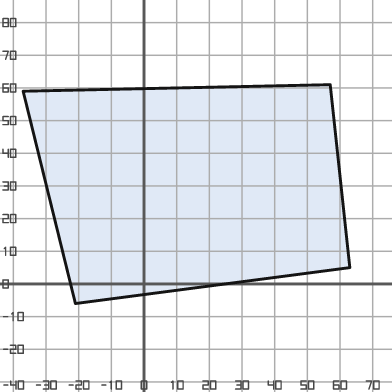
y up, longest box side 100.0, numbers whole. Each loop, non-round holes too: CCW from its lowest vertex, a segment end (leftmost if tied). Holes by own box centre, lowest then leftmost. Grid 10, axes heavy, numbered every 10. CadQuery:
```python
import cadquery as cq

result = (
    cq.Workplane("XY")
    .moveTo(-21.0, -6.0)
    .lineTo(63.0, 5.0)
    .lineTo(57.0, 61.0)
    .lineTo(-37.0, 59.0)
    .close()
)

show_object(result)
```